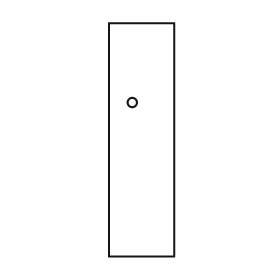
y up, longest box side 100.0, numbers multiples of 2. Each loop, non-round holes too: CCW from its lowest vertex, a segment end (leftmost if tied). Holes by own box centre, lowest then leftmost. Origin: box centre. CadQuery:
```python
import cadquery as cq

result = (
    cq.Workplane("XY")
    .moveTo(-14.0, -50.0)
    .lineTo(14.0, -50.0)
    .lineTo(14.0, 50.0)
    .lineTo(-14.0, 50.0)
    .close()
    .moveTo(-4.0, 16.0)
    .circle(2.0)
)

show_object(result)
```